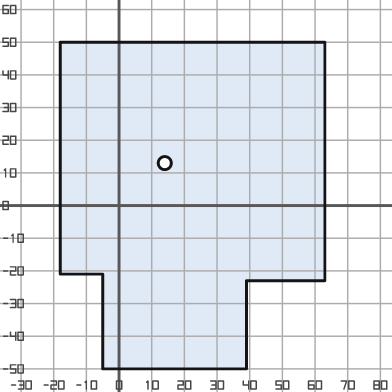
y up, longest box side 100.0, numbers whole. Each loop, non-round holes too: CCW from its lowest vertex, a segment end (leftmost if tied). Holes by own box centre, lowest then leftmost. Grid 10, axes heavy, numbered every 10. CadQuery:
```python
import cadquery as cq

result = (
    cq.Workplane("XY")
    .moveTo(-5.0, -50.0)
    .lineTo(39.0, -50.0)
    .lineTo(39.0, -23.0)
    .lineTo(63.0, -23.0)
    .lineTo(63.0, 50.0)
    .lineTo(-18.0, 50.0)
    .lineTo(-18.0, -21.0)
    .lineTo(-5.0, -21.0)
    .close()
    .moveTo(14.0, 13.0)
    .circle(2.0)
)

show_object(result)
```